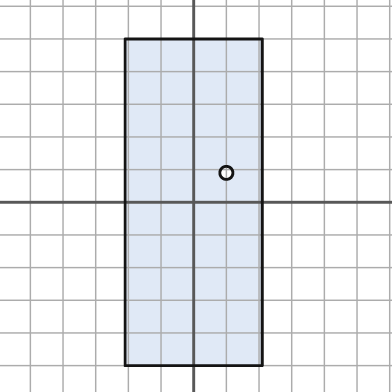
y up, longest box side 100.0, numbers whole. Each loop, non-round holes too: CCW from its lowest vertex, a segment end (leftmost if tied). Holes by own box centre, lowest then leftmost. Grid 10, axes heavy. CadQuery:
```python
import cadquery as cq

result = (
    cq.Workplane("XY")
    .moveTo(-21.0, -50.0)
    .lineTo(21.0, -50.0)
    .lineTo(21.0, 50.0)
    .lineTo(-21.0, 50.0)
    .close()
    .moveTo(10.0, 9.0)
    .circle(2.0)
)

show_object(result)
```